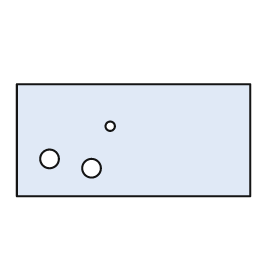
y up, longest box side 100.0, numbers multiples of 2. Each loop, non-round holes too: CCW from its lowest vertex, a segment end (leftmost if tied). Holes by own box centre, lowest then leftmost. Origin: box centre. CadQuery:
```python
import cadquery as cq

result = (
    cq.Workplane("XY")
    .moveTo(-50.0, -24.0)
    .lineTo(50.0, -24.0)
    .lineTo(50.0, 24.0)
    .lineTo(-50.0, 24.0)
    .close()
    .moveTo(-18.0, -12.0)
    .circle(4.0)
    .moveTo(-36.0, -8.0)
    .circle(4.0)
    .moveTo(-10.0, 6.0)
    .circle(2.0)
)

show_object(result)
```